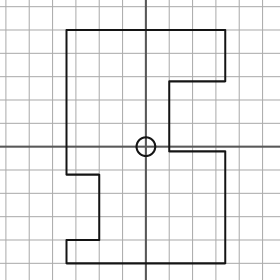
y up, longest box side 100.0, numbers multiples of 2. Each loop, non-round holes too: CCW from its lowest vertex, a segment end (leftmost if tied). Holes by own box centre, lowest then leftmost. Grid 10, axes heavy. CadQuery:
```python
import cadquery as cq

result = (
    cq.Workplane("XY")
    .moveTo(-34.0, -50.0)
    .lineTo(34.0, -50.0)
    .lineTo(34.0, -2.0)
    .lineTo(10.0, -2.0)
    .lineTo(10.0, 28.0)
    .lineTo(34.0, 28.0)
    .lineTo(34.0, 50.0)
    .lineTo(-34.0, 50.0)
    .lineTo(-34.0, -12.0)
    .lineTo(-20.0, -12.0)
    .lineTo(-20.0, -40.0)
    .lineTo(-34.0, -40.0)
    .close()
    .moveTo(0.0, 0.0)
    .circle(4.0)
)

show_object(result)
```